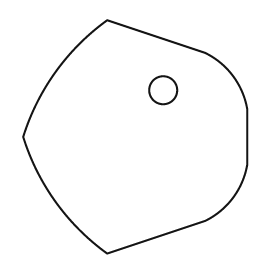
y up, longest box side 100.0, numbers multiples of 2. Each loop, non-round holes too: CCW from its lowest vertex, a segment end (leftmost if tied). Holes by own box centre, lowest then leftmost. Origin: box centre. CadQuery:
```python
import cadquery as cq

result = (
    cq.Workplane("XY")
    .moveTo(-12.0, -50.0)
    .lineTo(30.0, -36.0)
    .threePointArc((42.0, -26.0), (48.0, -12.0))
    .lineTo(48.0, 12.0)
    .threePointArc((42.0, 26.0), (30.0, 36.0))
    .lineTo(-12.0, 50.0)
    .threePointArc((-34.0, 28.0), (-48.0, 0.0))
    .threePointArc((-34.0, -28.0), (-12.0, -50.0))
    .close()
    .moveTo(12.0, 20.0)
    .circle(6.0)
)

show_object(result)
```